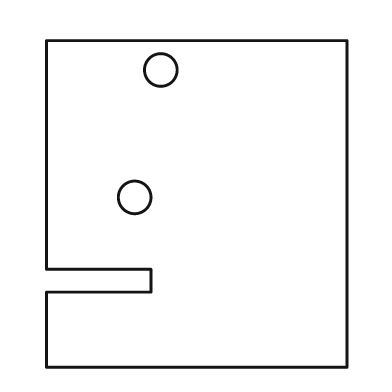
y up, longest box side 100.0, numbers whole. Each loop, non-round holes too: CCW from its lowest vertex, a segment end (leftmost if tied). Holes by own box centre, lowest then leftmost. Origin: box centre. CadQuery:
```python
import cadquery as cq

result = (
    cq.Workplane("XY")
    .moveTo(-46.0, -50.0)
    .lineTo(46.0, -50.0)
    .lineTo(46.0, 50.0)
    .lineTo(-46.0, 50.0)
    .lineTo(-46.0, -20.0)
    .lineTo(-14.0, -20.0)
    .lineTo(-14.0, -27.0)
    .lineTo(-46.0, -27.0)
    .close()
    .moveTo(-19.0, 2.0)
    .circle(5.0)
    .moveTo(-11.0, 41.0)
    .circle(5.0)
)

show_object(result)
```